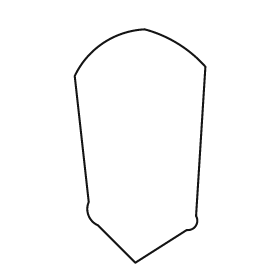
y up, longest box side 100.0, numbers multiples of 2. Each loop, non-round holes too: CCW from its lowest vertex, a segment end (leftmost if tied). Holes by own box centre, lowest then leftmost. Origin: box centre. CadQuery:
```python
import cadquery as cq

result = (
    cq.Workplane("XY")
    .moveTo(-2.0, -50.0)
    .lineTo(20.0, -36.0)
    .threePointArc((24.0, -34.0), (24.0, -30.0))
    .lineTo(28.0, 34.0)
    .threePointArc((16.0, 44.0), (2.0, 50.0))
    .threePointArc((-16.0, 44.0), (-28.0, 30.0))
    .lineTo(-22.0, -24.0)
    .threePointArc((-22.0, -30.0), (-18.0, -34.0))
    .close()
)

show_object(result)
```